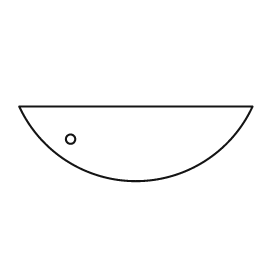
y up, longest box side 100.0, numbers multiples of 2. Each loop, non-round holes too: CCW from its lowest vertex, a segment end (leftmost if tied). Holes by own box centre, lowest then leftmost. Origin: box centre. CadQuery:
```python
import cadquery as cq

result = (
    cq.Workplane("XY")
    .moveTo(-50.0, 16.0)
    .threePointArc((0.0, -16.0), (50.0, 16.0))
    .close()
    .moveTo(-28.0, 2.0)
    .circle(2.0)
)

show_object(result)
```